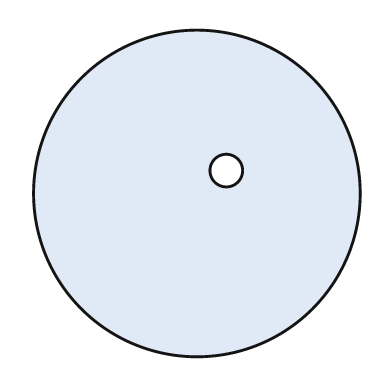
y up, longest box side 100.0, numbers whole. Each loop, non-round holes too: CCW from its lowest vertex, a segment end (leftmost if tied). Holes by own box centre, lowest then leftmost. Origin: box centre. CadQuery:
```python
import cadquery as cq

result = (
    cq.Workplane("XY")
    .moveTo(0.0, 0.0)
    .circle(50.0)
    .moveTo(9.0, 7.0)
    .circle(5.0)
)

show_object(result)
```